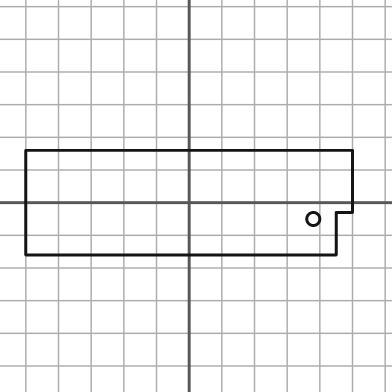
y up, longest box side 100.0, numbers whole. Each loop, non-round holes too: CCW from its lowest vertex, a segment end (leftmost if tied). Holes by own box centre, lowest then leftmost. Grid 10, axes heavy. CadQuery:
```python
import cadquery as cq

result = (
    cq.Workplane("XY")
    .moveTo(-50.0, -16.0)
    .lineTo(45.0, -16.0)
    .lineTo(45.0, -3.0)
    .lineTo(50.0, -3.0)
    .lineTo(50.0, 16.0)
    .lineTo(-50.0, 16.0)
    .close()
    .moveTo(38.0, -5.0)
    .circle(2.0)
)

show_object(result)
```